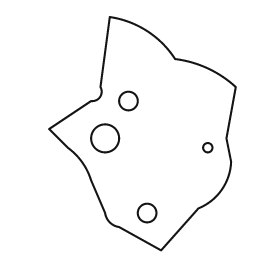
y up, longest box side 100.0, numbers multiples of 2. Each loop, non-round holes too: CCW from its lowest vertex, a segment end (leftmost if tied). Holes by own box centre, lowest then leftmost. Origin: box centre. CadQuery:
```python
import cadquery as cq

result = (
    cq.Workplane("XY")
    .moveTo(8.0, -50.0)
    .lineTo(24.0, -32.0)
    .threePointArc((34.0, -24.0), (38.0, -12.0))
    .lineTo(36.0, -2.0)
    .lineTo(40.0, 20.0)
    .threePointArc((28.0, 28.0), (14.0, 32.0))
    .threePointArc((2.0, 44.0), (-14.0, 50.0))
    .lineTo(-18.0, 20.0)
    .threePointArc((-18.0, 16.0), (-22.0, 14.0))
    .lineTo(-40.0, 2.0)
    .lineTo(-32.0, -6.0)
    .threePointArc((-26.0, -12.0), (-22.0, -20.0))
    .lineTo(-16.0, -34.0)
    .threePointArc((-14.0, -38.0), (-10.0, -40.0))
    .close()
    .moveTo(2.0, -34.0)
    .circle(4.0)
    .moveTo(28.0, -6.0)
    .circle(2.0)
    .moveTo(-16.0, -2.0)
    .circle(6.0)
    .moveTo(-6.0, 14.0)
    .circle(4.0)
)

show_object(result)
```